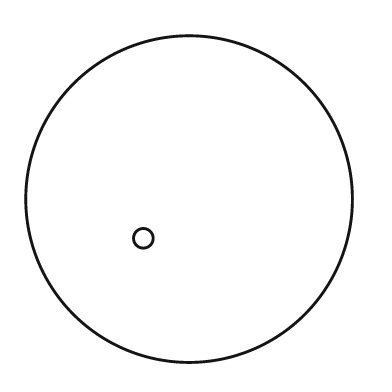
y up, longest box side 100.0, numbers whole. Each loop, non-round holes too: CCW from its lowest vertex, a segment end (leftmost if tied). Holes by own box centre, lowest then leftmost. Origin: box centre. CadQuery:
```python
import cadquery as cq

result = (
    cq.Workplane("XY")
    .moveTo(0.0, 0.0)
    .circle(50.0)
    .moveTo(-14.0, -12.0)
    .circle(3.0)
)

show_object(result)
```